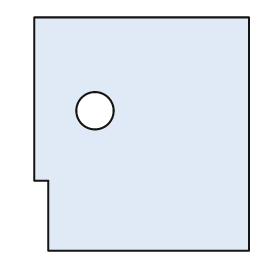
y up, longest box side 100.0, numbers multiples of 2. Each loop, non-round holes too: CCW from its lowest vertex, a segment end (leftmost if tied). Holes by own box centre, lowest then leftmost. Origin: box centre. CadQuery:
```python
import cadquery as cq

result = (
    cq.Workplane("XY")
    .moveTo(-40.0, -50.0)
    .lineTo(46.0, -50.0)
    .lineTo(46.0, 50.0)
    .lineTo(-46.0, 50.0)
    .lineTo(-46.0, -20.0)
    .lineTo(-40.0, -20.0)
    .close()
    .moveTo(-20.0, 10.0)
    .circle(8.0)
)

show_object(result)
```